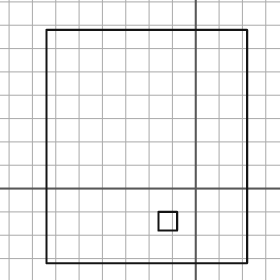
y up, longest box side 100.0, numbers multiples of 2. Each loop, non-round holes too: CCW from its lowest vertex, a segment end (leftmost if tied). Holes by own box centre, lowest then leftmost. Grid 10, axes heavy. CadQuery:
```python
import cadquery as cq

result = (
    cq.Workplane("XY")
    .moveTo(-64.0, -32.0)
    .lineTo(22.0, -32.0)
    .lineTo(22.0, 68.0)
    .lineTo(-64.0, 68.0)
    .close()
    .moveTo(-16.0, -18.0)
    .lineTo(-8.0, -18.0)
    .lineTo(-8.0, -10.0)
    .lineTo(-16.0, -10.0)
    .close()
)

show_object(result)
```